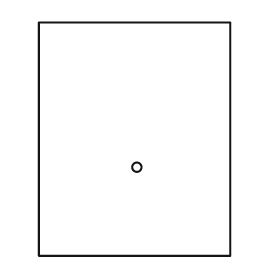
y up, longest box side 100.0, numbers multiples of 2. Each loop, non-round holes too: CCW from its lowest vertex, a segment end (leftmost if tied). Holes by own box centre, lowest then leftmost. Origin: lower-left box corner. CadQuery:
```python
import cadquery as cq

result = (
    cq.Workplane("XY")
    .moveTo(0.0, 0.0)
    .lineTo(82.0, 0.0)
    .lineTo(82.0, 100.0)
    .lineTo(0.0, 100.0)
    .close()
    .moveTo(42.0, 38.0)
    .circle(2.0)
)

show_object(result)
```